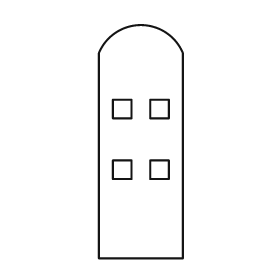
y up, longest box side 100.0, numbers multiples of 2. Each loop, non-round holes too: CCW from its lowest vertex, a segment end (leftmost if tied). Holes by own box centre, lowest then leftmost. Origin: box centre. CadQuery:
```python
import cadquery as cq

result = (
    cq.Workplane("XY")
    .moveTo(-18.0, -50.0)
    .lineTo(18.0, -50.0)
    .lineTo(18.0, 38.0)
    .threePointArc((0.0, 50.0), (-18.0, 38.0))
    .close()
    .moveTo(-12.0, -16.0)
    .lineTo(-4.0, -16.0)
    .lineTo(-4.0, -8.0)
    .lineTo(-12.0, -8.0)
    .close()
    .moveTo(4.0, -16.0)
    .lineTo(12.0, -16.0)
    .lineTo(12.0, -8.0)
    .lineTo(4.0, -8.0)
    .close()
    .moveTo(-12.0, 10.0)
    .lineTo(-4.0, 10.0)
    .lineTo(-4.0, 18.0)
    .lineTo(-12.0, 18.0)
    .close()
    .moveTo(4.0, 10.0)
    .lineTo(12.0, 10.0)
    .lineTo(12.0, 18.0)
    .lineTo(4.0, 18.0)
    .close()
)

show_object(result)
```